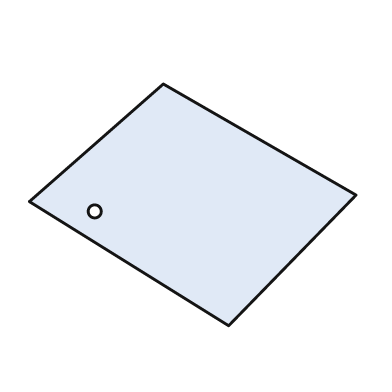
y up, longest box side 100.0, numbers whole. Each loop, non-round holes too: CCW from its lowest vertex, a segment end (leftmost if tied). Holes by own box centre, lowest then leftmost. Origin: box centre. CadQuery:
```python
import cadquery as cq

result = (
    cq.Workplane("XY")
    .moveTo(11.0, -37.0)
    .lineTo(50.0, 3.0)
    .lineTo(-9.0, 37.0)
    .lineTo(-50.0, 1.0)
    .close()
    .moveTo(-30.0, -2.0)
    .circle(2.0)
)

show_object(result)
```